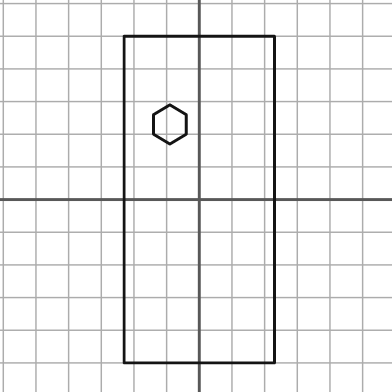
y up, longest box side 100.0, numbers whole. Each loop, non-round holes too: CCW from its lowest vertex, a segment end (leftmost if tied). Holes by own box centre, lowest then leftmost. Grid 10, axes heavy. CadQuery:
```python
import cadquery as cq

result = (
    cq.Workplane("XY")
    .moveTo(-23.0, -50.0)
    .lineTo(23.0, -50.0)
    .lineTo(23.0, 50.0)
    .lineTo(-23.0, 50.0)
    .close()
    .moveTo(-9.0, 17.0)
    .lineTo(-4.0, 20.0)
    .lineTo(-4.0, 26.0)
    .lineTo(-9.0, 29.0)
    .lineTo(-14.0, 26.0)
    .lineTo(-14.0, 20.0)
    .close()
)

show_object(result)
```